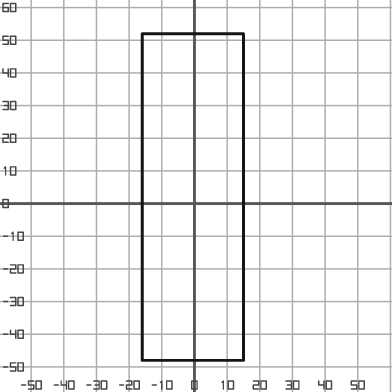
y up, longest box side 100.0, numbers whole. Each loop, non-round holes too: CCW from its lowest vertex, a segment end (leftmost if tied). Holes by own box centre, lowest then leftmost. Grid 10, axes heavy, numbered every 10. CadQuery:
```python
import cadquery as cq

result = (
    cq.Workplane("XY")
    .moveTo(-16.0, -48.0)
    .lineTo(15.0, -48.0)
    .lineTo(15.0, 52.0)
    .lineTo(-16.0, 52.0)
    .close()
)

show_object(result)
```